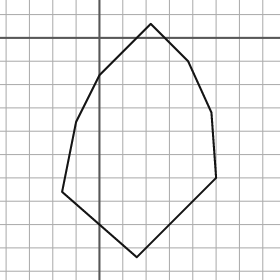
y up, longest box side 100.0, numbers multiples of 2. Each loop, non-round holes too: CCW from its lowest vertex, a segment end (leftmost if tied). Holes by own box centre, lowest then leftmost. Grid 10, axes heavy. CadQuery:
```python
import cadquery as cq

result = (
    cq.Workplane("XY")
    .moveTo(16.0, -94.0)
    .lineTo(50.0, -60.0)
    .lineTo(48.0, -32.0)
    .lineTo(38.0, -10.0)
    .lineTo(22.0, 6.0)
    .lineTo(0.0, -16.0)
    .lineTo(-10.0, -36.0)
    .lineTo(-16.0, -66.0)
    .close()
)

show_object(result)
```